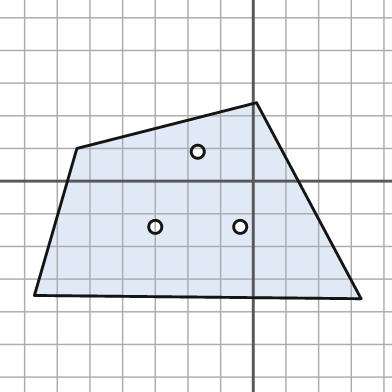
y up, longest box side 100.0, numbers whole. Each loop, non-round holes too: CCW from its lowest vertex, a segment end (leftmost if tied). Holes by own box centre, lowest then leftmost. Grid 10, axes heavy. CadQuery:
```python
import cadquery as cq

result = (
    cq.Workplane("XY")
    .moveTo(33.0, -36.0)
    .lineTo(1.0, 24.0)
    .lineTo(-54.0, 10.0)
    .lineTo(-67.0, -35.0)
    .close()
    .moveTo(-30.0, -14.0)
    .circle(2.0)
    .moveTo(-4.0, -14.0)
    .circle(2.0)
    .moveTo(-17.0, 9.0)
    .circle(2.0)
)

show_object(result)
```